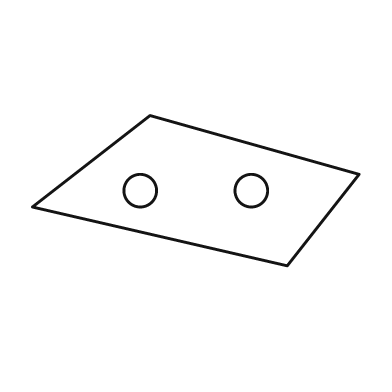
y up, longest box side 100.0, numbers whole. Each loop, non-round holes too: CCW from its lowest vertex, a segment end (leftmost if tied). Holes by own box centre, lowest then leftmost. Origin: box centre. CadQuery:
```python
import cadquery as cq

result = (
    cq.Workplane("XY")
    .moveTo(28.0, -23.0)
    .lineTo(50.0, 5.0)
    .lineTo(-14.0, 23.0)
    .lineTo(-50.0, -5.0)
    .close()
    .moveTo(-17.0, 0.0)
    .circle(5.0)
    .moveTo(17.0, 0.0)
    .circle(5.0)
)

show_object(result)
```